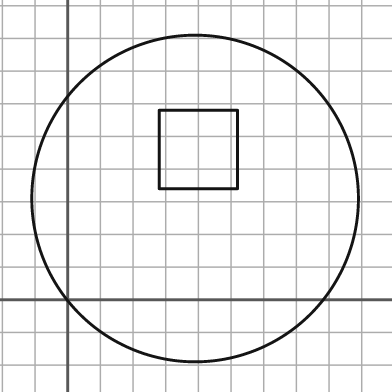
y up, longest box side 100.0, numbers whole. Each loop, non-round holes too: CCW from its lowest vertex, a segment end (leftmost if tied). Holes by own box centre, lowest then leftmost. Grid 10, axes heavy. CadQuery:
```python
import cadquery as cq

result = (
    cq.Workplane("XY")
    .moveTo(39.0, 31.0)
    .circle(50.0)
    .moveTo(28.0, 34.0)
    .lineTo(52.0, 34.0)
    .lineTo(52.0, 58.0)
    .lineTo(28.0, 58.0)
    .close()
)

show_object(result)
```